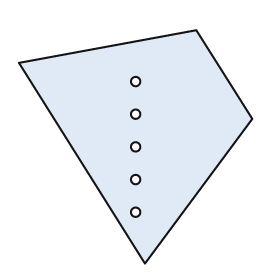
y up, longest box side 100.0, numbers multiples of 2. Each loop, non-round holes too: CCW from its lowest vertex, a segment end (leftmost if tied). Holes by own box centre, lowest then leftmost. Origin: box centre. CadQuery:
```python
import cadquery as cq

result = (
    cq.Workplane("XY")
    .moveTo(4.0, -50.0)
    .lineTo(50.0, 12.0)
    .lineTo(26.0, 50.0)
    .lineTo(-50.0, 36.0)
    .close()
    .moveTo(0.0, -28.0)
    .circle(2.0)
    .moveTo(0.0, -14.0)
    .circle(2.0)
    .moveTo(0.0, 0.0)
    .circle(2.0)
    .moveTo(0.0, 14.0)
    .circle(2.0)
    .moveTo(0.0, 28.0)
    .circle(2.0)
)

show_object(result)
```